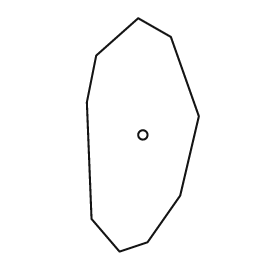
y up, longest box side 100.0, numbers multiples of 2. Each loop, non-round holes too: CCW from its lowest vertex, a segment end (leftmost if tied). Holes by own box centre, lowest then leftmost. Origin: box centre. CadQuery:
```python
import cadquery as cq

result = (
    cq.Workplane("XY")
    .moveTo(-10.0, -50.0)
    .lineTo(2.0, -46.0)
    .lineTo(16.0, -26.0)
    .lineTo(24.0, 8.0)
    .lineTo(12.0, 42.0)
    .lineTo(-2.0, 50.0)
    .lineTo(-20.0, 34.0)
    .lineTo(-24.0, 14.0)
    .lineTo(-22.0, -36.0)
    .close()
    .moveTo(0.0, 0.0)
    .circle(2.0)
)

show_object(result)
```